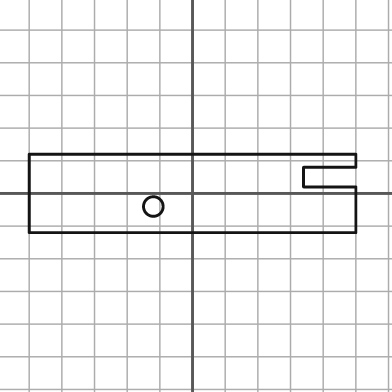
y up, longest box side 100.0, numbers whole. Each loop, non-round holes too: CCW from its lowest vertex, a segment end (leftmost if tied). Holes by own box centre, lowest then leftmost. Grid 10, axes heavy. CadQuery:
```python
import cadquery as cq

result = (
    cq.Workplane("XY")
    .moveTo(-50.0, -12.0)
    .lineTo(50.0, -12.0)
    .lineTo(50.0, 2.0)
    .lineTo(34.0, 2.0)
    .lineTo(34.0, 8.0)
    .lineTo(50.0, 8.0)
    .lineTo(50.0, 12.0)
    .lineTo(-50.0, 12.0)
    .close()
    .moveTo(-12.0, -4.0)
    .circle(3.0)
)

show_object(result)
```